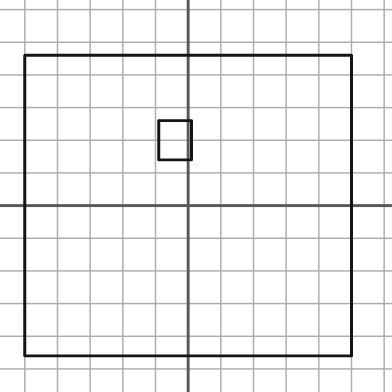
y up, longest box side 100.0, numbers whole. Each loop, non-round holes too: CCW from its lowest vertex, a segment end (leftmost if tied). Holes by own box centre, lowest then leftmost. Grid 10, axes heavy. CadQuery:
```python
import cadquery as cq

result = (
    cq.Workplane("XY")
    .moveTo(-50.0, -46.0)
    .lineTo(50.0, -46.0)
    .lineTo(50.0, 46.0)
    .lineTo(-50.0, 46.0)
    .close()
    .moveTo(-9.0, 14.0)
    .lineTo(1.0, 14.0)
    .lineTo(1.0, 26.0)
    .lineTo(-9.0, 26.0)
    .close()
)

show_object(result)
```